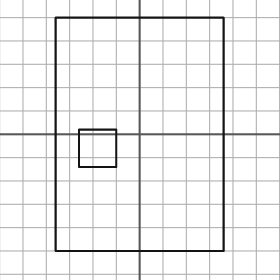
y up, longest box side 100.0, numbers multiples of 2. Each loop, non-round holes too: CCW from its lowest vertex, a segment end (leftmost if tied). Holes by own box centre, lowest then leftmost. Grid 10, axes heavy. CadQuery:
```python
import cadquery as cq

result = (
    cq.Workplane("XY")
    .moveTo(-36.0, -50.0)
    .lineTo(36.0, -50.0)
    .lineTo(36.0, 50.0)
    .lineTo(-36.0, 50.0)
    .close()
    .moveTo(-26.0, -14.0)
    .lineTo(-10.0, -14.0)
    .lineTo(-10.0, 2.0)
    .lineTo(-26.0, 2.0)
    .close()
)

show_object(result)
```